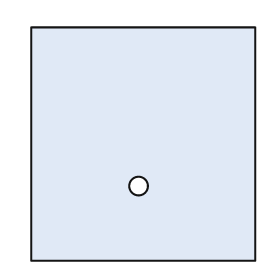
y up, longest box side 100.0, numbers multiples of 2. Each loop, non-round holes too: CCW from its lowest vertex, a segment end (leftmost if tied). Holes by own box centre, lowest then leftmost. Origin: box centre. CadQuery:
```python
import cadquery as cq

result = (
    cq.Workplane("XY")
    .moveTo(-48.0, -50.0)
    .lineTo(48.0, -50.0)
    .lineTo(48.0, 50.0)
    .lineTo(-48.0, 50.0)
    .close()
    .moveTo(-2.0, -18.0)
    .circle(4.0)
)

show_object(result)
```